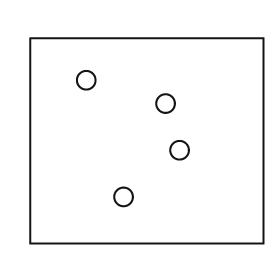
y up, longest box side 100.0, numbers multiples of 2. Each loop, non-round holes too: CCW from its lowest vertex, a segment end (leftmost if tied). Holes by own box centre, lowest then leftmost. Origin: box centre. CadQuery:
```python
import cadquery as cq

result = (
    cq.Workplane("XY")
    .moveTo(-50.0, -44.0)
    .lineTo(50.0, -44.0)
    .lineTo(50.0, 44.0)
    .lineTo(-50.0, 44.0)
    .close()
    .moveTo(-10.0, -24.0)
    .circle(4.0)
    .moveTo(14.0, -4.0)
    .circle(4.0)
    .moveTo(8.0, 16.0)
    .circle(4.0)
    .moveTo(-26.0, 26.0)
    .circle(4.0)
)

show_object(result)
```